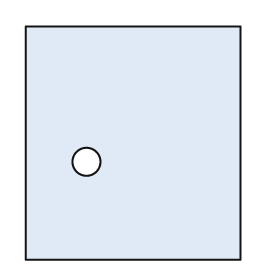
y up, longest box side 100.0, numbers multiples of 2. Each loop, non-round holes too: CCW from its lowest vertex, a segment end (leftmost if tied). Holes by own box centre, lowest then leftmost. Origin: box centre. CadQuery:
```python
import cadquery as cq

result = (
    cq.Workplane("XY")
    .moveTo(-46.0, -50.0)
    .lineTo(46.0, -50.0)
    .lineTo(46.0, 50.0)
    .lineTo(-46.0, 50.0)
    .close()
    .moveTo(-20.0, -8.0)
    .circle(6.0)
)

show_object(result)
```